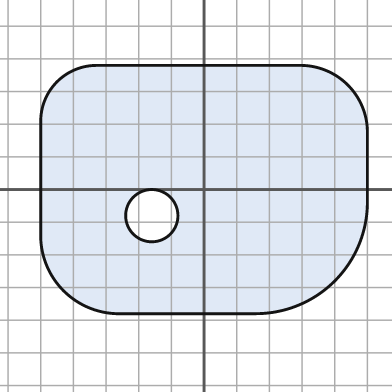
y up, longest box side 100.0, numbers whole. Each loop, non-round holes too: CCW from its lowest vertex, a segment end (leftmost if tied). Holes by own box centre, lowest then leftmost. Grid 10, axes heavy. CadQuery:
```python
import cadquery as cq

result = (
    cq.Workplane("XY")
    .moveTo(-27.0, -38.0)
    .lineTo(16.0, -38.0)
    .threePointArc((40.0, -28.0), (50.0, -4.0))
    .lineTo(50.0, 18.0)
    .threePointArc((44.0, 32.0), (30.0, 38.0))
    .lineTo(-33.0, 38.0)
    .threePointArc((-45.0, 33.0), (-50.0, 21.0))
    .lineTo(-50.0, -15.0)
    .threePointArc((-43.0, -31.0), (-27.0, -38.0))
    .close()
    .moveTo(-16.0, -8.0)
    .circle(8.0)
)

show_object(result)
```